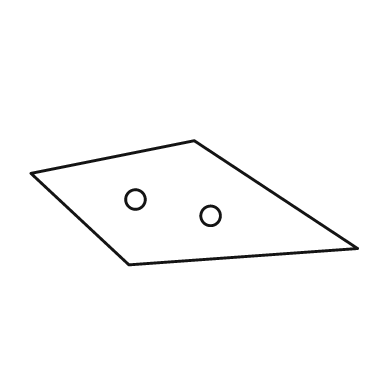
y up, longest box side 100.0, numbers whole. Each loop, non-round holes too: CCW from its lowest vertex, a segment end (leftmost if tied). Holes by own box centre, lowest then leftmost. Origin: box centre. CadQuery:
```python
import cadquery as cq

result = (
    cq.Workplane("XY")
    .moveTo(-20.0, -19.0)
    .lineTo(50.0, -14.0)
    .lineTo(0.0, 19.0)
    .lineTo(-50.0, 9.0)
    .close()
    .moveTo(5.0, -4.0)
    .circle(3.0)
    .moveTo(-18.0, 1.0)
    .circle(3.0)
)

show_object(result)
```